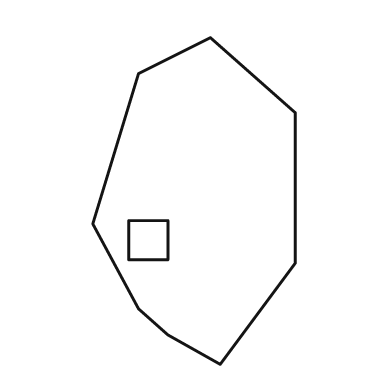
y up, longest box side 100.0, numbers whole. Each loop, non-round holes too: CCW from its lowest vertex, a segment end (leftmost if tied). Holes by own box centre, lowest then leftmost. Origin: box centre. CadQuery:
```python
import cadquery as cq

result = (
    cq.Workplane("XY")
    .moveTo(8.0, -50.0)
    .lineTo(31.0, -19.0)
    .lineTo(31.0, 27.0)
    .lineTo(5.0, 50.0)
    .lineTo(-17.0, 39.0)
    .lineTo(-31.0, -7.0)
    .lineTo(-17.0, -33.0)
    .lineTo(-8.0, -41.0)
    .close()
    .moveTo(-20.0, -18.0)
    .lineTo(-8.0, -18.0)
    .lineTo(-8.0, -6.0)
    .lineTo(-20.0, -6.0)
    .close()
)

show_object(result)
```